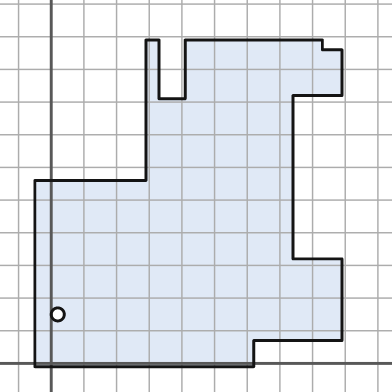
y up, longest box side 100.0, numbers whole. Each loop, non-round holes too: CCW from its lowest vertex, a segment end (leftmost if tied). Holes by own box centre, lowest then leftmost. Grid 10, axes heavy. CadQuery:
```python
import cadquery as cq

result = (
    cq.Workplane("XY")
    .moveTo(-5.0, -1.0)
    .lineTo(62.0, -1.0)
    .lineTo(62.0, 7.0)
    .lineTo(89.0, 7.0)
    .lineTo(89.0, 32.0)
    .lineTo(74.0, 32.0)
    .lineTo(74.0, 82.0)
    .lineTo(89.0, 82.0)
    .lineTo(89.0, 96.0)
    .lineTo(83.0, 96.0)
    .lineTo(83.0, 99.0)
    .lineTo(41.0, 99.0)
    .lineTo(41.0, 81.0)
    .lineTo(33.0, 81.0)
    .lineTo(33.0, 99.0)
    .lineTo(29.0, 99.0)
    .lineTo(29.0, 56.0)
    .lineTo(-5.0, 56.0)
    .close()
    .moveTo(2.0, 15.0)
    .circle(2.0)
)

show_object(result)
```